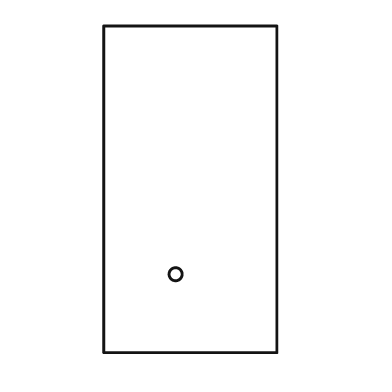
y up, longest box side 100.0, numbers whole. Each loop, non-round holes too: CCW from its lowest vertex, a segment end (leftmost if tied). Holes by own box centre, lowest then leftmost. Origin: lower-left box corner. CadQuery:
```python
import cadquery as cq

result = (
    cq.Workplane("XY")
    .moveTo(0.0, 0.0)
    .lineTo(53.0, 0.0)
    .lineTo(53.0, 100.0)
    .lineTo(0.0, 100.0)
    .close()
    .moveTo(22.0, 24.0)
    .circle(2.0)
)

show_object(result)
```